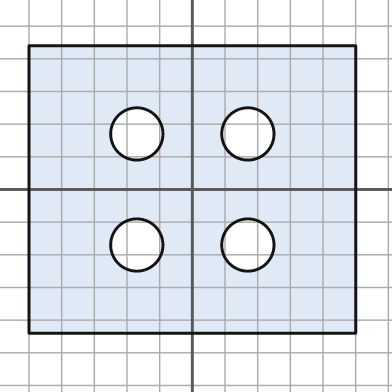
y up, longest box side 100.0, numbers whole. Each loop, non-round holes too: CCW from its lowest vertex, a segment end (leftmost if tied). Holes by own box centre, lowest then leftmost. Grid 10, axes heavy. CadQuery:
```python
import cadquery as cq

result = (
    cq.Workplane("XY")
    .moveTo(-50.0, -44.0)
    .lineTo(50.0, -44.0)
    .lineTo(50.0, 44.0)
    .lineTo(-50.0, 44.0)
    .close()
    .moveTo(-17.0, -17.0)
    .circle(8.0)
    .moveTo(17.0, -17.0)
    .circle(8.0)
    .moveTo(-17.0, 17.0)
    .circle(8.0)
    .moveTo(17.0, 17.0)
    .circle(8.0)
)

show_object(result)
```